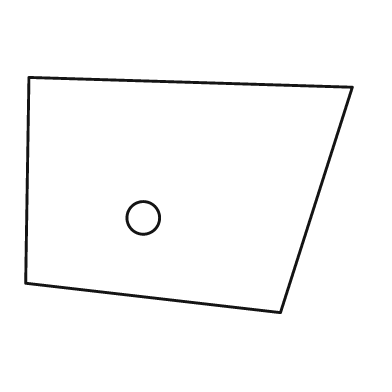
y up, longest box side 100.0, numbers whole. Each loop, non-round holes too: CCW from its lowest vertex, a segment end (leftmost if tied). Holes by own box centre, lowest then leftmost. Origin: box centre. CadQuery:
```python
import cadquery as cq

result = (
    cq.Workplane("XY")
    .moveTo(28.0, -36.0)
    .lineTo(50.0, 33.0)
    .lineTo(-49.0, 36.0)
    .lineTo(-50.0, -27.0)
    .close()
    .moveTo(-14.0, -7.0)
    .circle(5.0)
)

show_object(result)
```